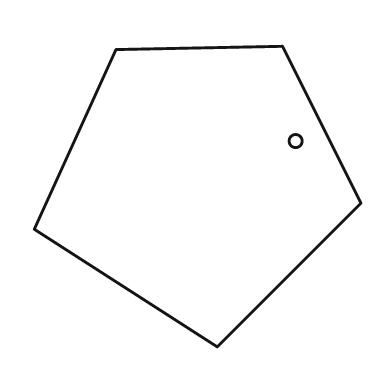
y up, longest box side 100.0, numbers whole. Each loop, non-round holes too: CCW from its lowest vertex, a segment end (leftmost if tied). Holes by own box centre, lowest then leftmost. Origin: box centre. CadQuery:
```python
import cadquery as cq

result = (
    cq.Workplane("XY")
    .moveTo(6.0, -46.0)
    .lineTo(50.0, -2.0)
    .lineTo(26.0, 46.0)
    .lineTo(-25.0, 45.0)
    .lineTo(-50.0, -10.0)
    .close()
    .moveTo(30.0, 17.0)
    .circle(2.0)
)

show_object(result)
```